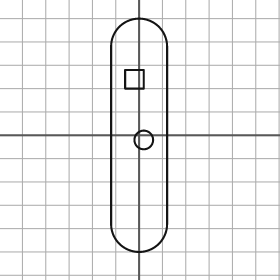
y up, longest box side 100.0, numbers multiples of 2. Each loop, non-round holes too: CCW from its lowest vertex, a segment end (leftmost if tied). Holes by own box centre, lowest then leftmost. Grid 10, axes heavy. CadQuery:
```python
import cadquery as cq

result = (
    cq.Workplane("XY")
    .moveTo(-12.0, -38.0)
    .threePointArc((0.0, -50.0), (12.0, -38.0))
    .lineTo(12.0, 38.0)
    .threePointArc((0.0, 50.0), (-12.0, 38.0))
    .close()
    .moveTo(2.0, -2.0)
    .circle(4.0)
    .moveTo(-6.0, 20.0)
    .lineTo(2.0, 20.0)
    .lineTo(2.0, 28.0)
    .lineTo(-6.0, 28.0)
    .close()
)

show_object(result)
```